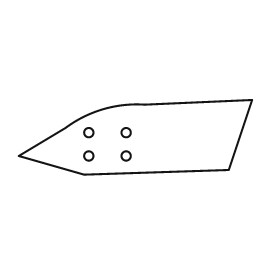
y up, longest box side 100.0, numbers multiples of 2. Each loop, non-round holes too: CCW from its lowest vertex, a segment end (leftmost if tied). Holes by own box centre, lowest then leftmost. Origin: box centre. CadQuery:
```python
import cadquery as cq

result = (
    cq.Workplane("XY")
    .moveTo(-22.0, -16.0)
    .lineTo(40.0, -14.0)
    .lineTo(50.0, 16.0)
    .lineTo(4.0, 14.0)
    .threePointArc((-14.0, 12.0), (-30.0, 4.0))
    .lineTo(-50.0, -8.0)
    .close()
    .moveTo(-20.0, -8.0)
    .circle(2.0)
    .moveTo(-4.0, -8.0)
    .circle(2.0)
    .moveTo(-20.0, 2.0)
    .circle(2.0)
    .moveTo(-4.0, 2.0)
    .circle(2.0)
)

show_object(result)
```